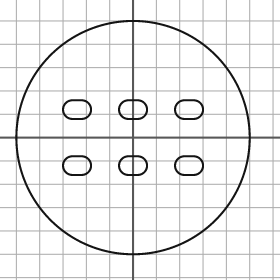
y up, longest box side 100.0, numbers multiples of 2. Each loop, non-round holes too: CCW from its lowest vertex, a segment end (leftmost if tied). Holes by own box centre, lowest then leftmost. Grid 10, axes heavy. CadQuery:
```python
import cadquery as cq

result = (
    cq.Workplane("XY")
    .moveTo(0.0, 0.0)
    .circle(50.0)
    .moveTo(-26.0, -16.0)
    .lineTo(-22.0, -16.0)
    .threePointArc((-18.0, -12.0), (-22.0, -8.0))
    .lineTo(-26.0, -8.0)
    .threePointArc((-30.0, -12.0), (-26.0, -16.0))
    .close()
    .moveTo(-2.0, -16.0)
    .lineTo(2.0, -16.0)
    .threePointArc((6.0, -12.0), (2.0, -8.0))
    .lineTo(-2.0, -8.0)
    .threePointArc((-6.0, -12.0), (-2.0, -16.0))
    .close()
    .moveTo(22.0, -16.0)
    .lineTo(26.0, -16.0)
    .threePointArc((30.0, -12.0), (26.0, -8.0))
    .lineTo(22.0, -8.0)
    .threePointArc((18.0, -12.0), (22.0, -16.0))
    .close()
    .moveTo(-26.0, 8.0)
    .lineTo(-22.0, 8.0)
    .threePointArc((-18.0, 12.0), (-22.0, 16.0))
    .lineTo(-26.0, 16.0)
    .threePointArc((-30.0, 12.0), (-26.0, 8.0))
    .close()
    .moveTo(-2.0, 8.0)
    .lineTo(2.0, 8.0)
    .threePointArc((6.0, 12.0), (2.0, 16.0))
    .lineTo(-2.0, 16.0)
    .threePointArc((-6.0, 12.0), (-2.0, 8.0))
    .close()
    .moveTo(22.0, 8.0)
    .lineTo(26.0, 8.0)
    .threePointArc((30.0, 12.0), (26.0, 16.0))
    .lineTo(22.0, 16.0)
    .threePointArc((18.0, 12.0), (22.0, 8.0))
    .close()
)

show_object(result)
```